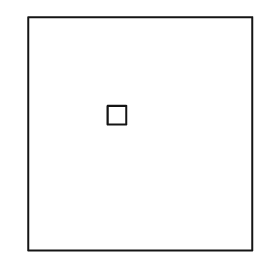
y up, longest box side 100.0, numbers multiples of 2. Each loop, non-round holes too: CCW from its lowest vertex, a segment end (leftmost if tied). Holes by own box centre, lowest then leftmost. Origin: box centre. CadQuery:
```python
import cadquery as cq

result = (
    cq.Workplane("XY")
    .moveTo(-48.0, -50.0)
    .lineTo(48.0, -50.0)
    .lineTo(48.0, 50.0)
    .lineTo(-48.0, 50.0)
    .close()
    .moveTo(-14.0, 4.0)
    .lineTo(-6.0, 4.0)
    .lineTo(-6.0, 12.0)
    .lineTo(-14.0, 12.0)
    .close()
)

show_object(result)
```